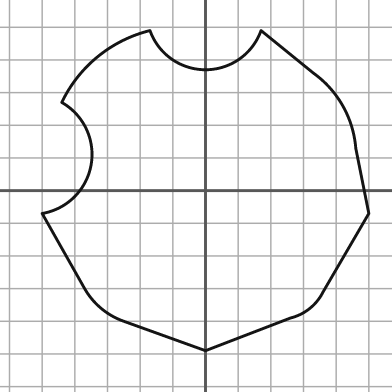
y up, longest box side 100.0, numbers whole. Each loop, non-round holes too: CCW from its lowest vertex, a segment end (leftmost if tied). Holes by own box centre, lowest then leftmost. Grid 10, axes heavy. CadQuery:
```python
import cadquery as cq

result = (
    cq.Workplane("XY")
    .moveTo(0.0, -49.0)
    .lineTo(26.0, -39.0)
    .threePointArc((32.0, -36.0), (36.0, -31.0))
    .lineTo(50.0, -7.0)
    .lineTo(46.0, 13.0)
    .threePointArc((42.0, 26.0), (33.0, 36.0))
    .lineTo(17.0, 49.0)
    .threePointArc((0.0, 37.0), (-17.0, 49.0))
    .threePointArc((-33.0, 41.0), (-44.0, 27.0))
    .threePointArc((-35.0, 8.0), (-50.0, -7.0))
    .lineTo(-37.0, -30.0)
    .threePointArc((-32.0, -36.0), (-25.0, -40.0))
    .close()
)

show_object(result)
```